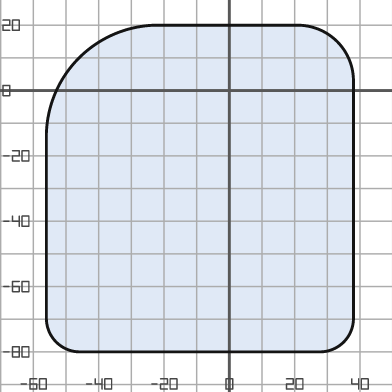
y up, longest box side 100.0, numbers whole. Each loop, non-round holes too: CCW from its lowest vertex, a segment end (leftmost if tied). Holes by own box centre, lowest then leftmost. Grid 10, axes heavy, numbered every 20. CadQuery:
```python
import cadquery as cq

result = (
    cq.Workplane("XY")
    .moveTo(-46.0, -80.0)
    .lineTo(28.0, -80.0)
    .threePointArc((35.0, -77.0), (38.0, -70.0))
    .lineTo(38.0, 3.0)
    .threePointArc((33.0, 15.0), (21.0, 20.0))
    .lineTo(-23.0, 20.0)
    .threePointArc((-46.0, 10.0), (-56.0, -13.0))
    .lineTo(-56.0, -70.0)
    .threePointArc((-53.0, -77.0), (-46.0, -80.0))
    .close()
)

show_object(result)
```